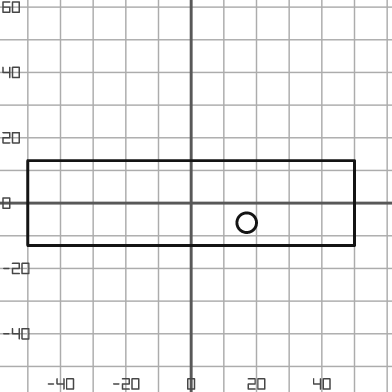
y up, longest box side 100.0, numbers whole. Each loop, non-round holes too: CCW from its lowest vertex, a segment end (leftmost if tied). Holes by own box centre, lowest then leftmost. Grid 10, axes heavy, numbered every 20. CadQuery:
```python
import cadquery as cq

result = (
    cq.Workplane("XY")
    .moveTo(-50.0, -13.0)
    .lineTo(50.0, -13.0)
    .lineTo(50.0, 13.0)
    .lineTo(-50.0, 13.0)
    .close()
    .moveTo(17.0, -6.0)
    .circle(3.0)
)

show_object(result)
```